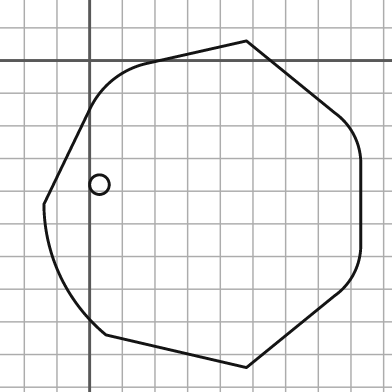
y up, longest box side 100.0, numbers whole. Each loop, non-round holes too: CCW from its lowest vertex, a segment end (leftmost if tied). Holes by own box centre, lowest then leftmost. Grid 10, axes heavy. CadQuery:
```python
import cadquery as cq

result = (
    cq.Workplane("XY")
    .moveTo(48.0, -94.0)
    .lineTo(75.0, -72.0)
    .threePointArc((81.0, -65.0), (83.0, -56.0))
    .lineTo(83.0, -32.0)
    .threePointArc((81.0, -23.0), (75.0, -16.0))
    .lineTo(48.0, 6.0)
    .lineTo(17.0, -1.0)
    .threePointArc((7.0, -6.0), (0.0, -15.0))
    .lineTo(-14.0, -44.0)
    .threePointArc((-9.0, -66.0), (5.0, -84.0))
    .close()
    .moveTo(3.0, -38.0)
    .circle(3.0)
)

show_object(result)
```